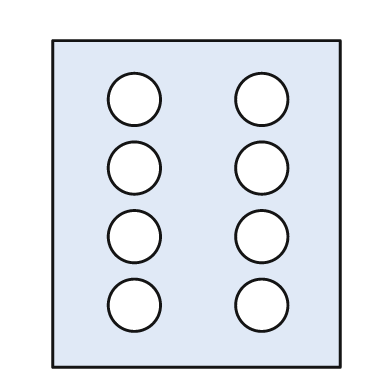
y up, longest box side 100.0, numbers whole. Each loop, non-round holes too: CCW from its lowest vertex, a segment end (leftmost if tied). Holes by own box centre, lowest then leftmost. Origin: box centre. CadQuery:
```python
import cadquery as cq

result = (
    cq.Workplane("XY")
    .moveTo(-44.0, -50.0)
    .lineTo(44.0, -50.0)
    .lineTo(44.0, 50.0)
    .lineTo(-44.0, 50.0)
    .close()
    .moveTo(-19.0, -31.0)
    .circle(8.0)
    .moveTo(20.0, -31.0)
    .circle(8.0)
    .moveTo(-19.0, -10.0)
    .circle(8.0)
    .moveTo(20.0, -10.0)
    .circle(8.0)
    .moveTo(-19.0, 11.0)
    .circle(8.0)
    .moveTo(20.0, 11.0)
    .circle(8.0)
    .moveTo(-19.0, 32.0)
    .circle(8.0)
    .moveTo(20.0, 32.0)
    .circle(8.0)
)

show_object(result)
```